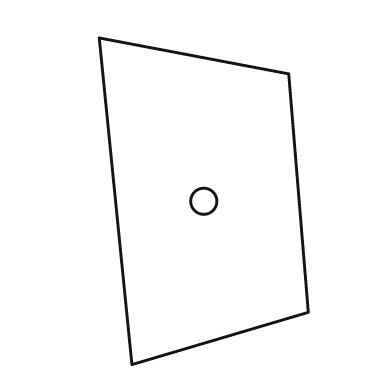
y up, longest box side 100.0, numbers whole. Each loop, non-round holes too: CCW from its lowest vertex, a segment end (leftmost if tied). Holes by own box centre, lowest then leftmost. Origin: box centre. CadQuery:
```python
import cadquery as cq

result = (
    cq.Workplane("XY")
    .moveTo(-22.0, -50.0)
    .lineTo(32.0, -34.0)
    .lineTo(26.0, 39.0)
    .lineTo(-32.0, 50.0)
    .close()
    .moveTo(0.0, 0.0)
    .circle(4.0)
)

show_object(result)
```